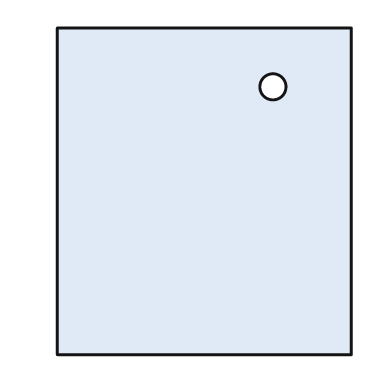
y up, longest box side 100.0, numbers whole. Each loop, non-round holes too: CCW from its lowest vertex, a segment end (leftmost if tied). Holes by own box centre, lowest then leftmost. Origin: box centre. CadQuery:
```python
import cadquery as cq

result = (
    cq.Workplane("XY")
    .moveTo(-45.0, -50.0)
    .lineTo(45.0, -50.0)
    .lineTo(45.0, 50.0)
    .lineTo(-45.0, 50.0)
    .close()
    .moveTo(21.0, 32.0)
    .circle(4.0)
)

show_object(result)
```